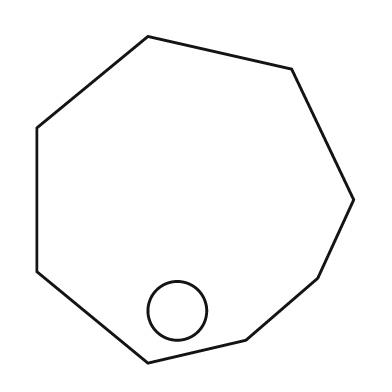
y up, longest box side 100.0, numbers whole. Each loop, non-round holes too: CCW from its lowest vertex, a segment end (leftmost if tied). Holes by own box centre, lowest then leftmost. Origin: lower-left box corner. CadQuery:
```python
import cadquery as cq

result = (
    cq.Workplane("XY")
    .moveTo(34.0, 0.0)
    .lineTo(64.0, 7.0)
    .lineTo(86.0, 26.0)
    .lineTo(97.0, 50.0)
    .lineTo(78.0, 90.0)
    .lineTo(34.0, 100.0)
    .lineTo(0.0, 72.0)
    .lineTo(0.0, 28.0)
    .close()
    .moveTo(43.0, 16.0)
    .circle(9.0)
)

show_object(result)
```